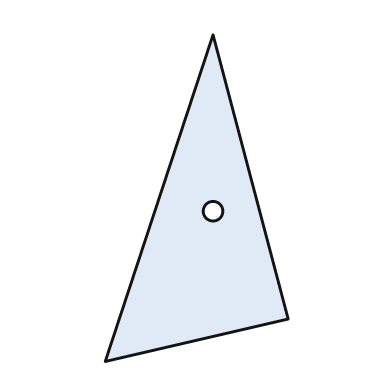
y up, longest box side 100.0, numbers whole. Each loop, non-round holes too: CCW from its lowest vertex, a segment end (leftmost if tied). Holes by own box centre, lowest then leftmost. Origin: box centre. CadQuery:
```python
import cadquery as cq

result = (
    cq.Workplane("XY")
    .moveTo(-28.0, -50.0)
    .lineTo(28.0, -37.0)
    .lineTo(5.0, 50.0)
    .close()
    .moveTo(5.0, -4.0)
    .circle(3.0)
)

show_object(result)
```